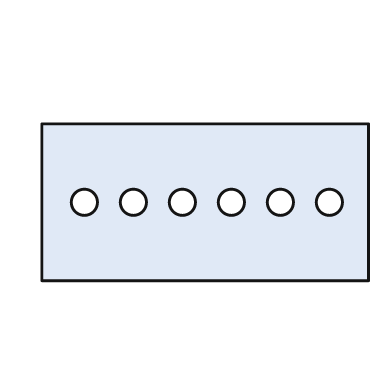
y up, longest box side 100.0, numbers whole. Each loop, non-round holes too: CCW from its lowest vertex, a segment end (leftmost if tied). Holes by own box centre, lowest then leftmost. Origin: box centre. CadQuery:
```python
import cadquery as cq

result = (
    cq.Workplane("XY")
    .moveTo(-50.0, -24.0)
    .lineTo(50.0, -24.0)
    .lineTo(50.0, 24.0)
    .lineTo(-50.0, 24.0)
    .close()
    .moveTo(-37.0, 0.0)
    .circle(4.0)
    .moveTo(-22.0, 0.0)
    .circle(4.0)
    .moveTo(-7.0, 0.0)
    .circle(4.0)
    .moveTo(8.0, 0.0)
    .circle(4.0)
    .moveTo(23.0, 0.0)
    .circle(4.0)
    .moveTo(38.0, 0.0)
    .circle(4.0)
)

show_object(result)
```